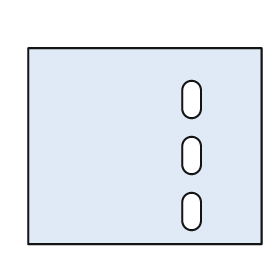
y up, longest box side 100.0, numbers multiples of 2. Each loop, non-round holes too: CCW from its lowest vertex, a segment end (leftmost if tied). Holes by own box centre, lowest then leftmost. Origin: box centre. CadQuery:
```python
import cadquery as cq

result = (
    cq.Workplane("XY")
    .moveTo(-50.0, -42.0)
    .lineTo(50.0, -42.0)
    .lineTo(50.0, 42.0)
    .lineTo(-50.0, 42.0)
    .close()
    .moveTo(16.0, -32.0)
    .threePointArc((20.0, -36.0), (24.0, -32.0))
    .lineTo(24.0, -24.0)
    .threePointArc((20.0, -20.0), (16.0, -24.0))
    .close()
    .moveTo(16.0, -8.0)
    .threePointArc((20.0, -12.0), (24.0, -8.0))
    .lineTo(24.0, 0.0)
    .threePointArc((20.0, 4.0), (16.0, 0.0))
    .close()
    .moveTo(16.0, 16.0)
    .threePointArc((20.0, 12.0), (24.0, 16.0))
    .lineTo(24.0, 24.0)
    .threePointArc((20.0, 28.0), (16.0, 24.0))
    .close()
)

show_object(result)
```